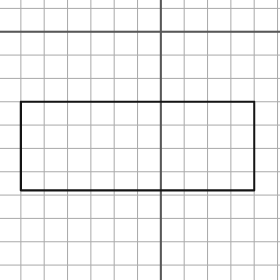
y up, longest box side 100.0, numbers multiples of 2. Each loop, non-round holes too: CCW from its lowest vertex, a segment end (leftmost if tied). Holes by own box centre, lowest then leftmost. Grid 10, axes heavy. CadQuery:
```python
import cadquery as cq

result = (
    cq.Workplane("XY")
    .moveTo(-60.0, -68.0)
    .lineTo(40.0, -68.0)
    .lineTo(40.0, -30.0)
    .lineTo(-60.0, -30.0)
    .close()
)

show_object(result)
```